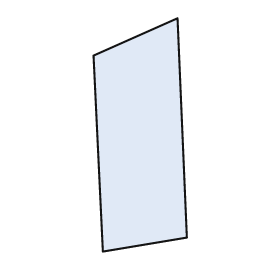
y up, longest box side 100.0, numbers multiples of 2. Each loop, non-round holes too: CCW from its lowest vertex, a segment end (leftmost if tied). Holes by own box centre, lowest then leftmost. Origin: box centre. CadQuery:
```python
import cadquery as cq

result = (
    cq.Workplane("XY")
    .moveTo(-16.0, -50.0)
    .lineTo(20.0, -44.0)
    .lineTo(16.0, 50.0)
    .lineTo(-20.0, 34.0)
    .close()
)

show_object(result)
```